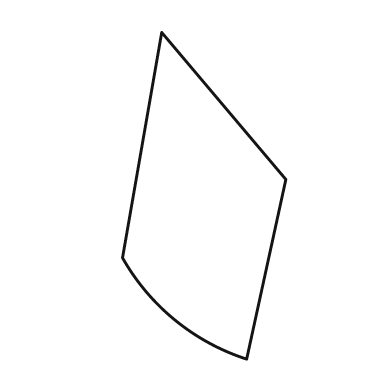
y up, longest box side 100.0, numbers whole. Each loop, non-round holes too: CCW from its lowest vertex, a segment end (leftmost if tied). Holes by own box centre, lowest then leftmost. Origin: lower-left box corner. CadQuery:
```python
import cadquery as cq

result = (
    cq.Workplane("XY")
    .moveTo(38.0, 0.0)
    .lineTo(50.0, 55.0)
    .lineTo(12.0, 100.0)
    .lineTo(0.0, 31.0)
    .threePointArc((16.0, 12.0), (38.0, 0.0))
    .close()
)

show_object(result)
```